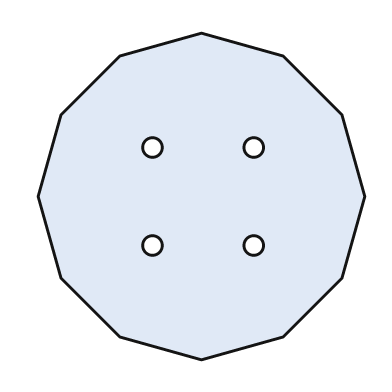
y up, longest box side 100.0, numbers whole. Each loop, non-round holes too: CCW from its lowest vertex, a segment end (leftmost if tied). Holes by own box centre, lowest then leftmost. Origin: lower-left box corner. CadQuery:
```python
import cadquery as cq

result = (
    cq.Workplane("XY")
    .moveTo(50.0, 0.0)
    .lineTo(75.0, 7.0)
    .lineTo(93.0, 25.0)
    .lineTo(100.0, 50.0)
    .lineTo(93.0, 75.0)
    .lineTo(75.0, 93.0)
    .lineTo(50.0, 100.0)
    .lineTo(25.0, 93.0)
    .lineTo(7.0, 75.0)
    .lineTo(0.0, 50.0)
    .lineTo(7.0, 25.0)
    .lineTo(25.0, 7.0)
    .close()
    .moveTo(35.0, 35.0)
    .circle(3.0)
    .moveTo(66.0, 35.0)
    .circle(3.0)
    .moveTo(35.0, 65.0)
    .circle(3.0)
    .moveTo(66.0, 65.0)
    .circle(3.0)
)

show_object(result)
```